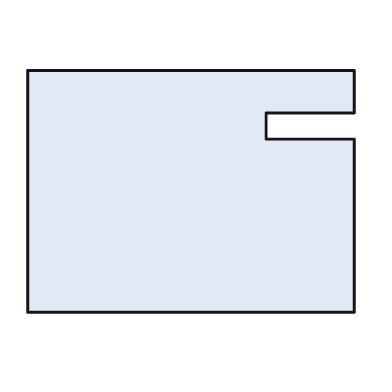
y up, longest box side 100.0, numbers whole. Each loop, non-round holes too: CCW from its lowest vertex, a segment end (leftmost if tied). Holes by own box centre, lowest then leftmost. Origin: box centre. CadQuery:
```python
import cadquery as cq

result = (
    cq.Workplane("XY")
    .moveTo(-50.0, -37.0)
    .lineTo(50.0, -37.0)
    .lineTo(50.0, 16.0)
    .lineTo(23.0, 16.0)
    .lineTo(23.0, 24.0)
    .lineTo(50.0, 24.0)
    .lineTo(50.0, 37.0)
    .lineTo(-50.0, 37.0)
    .close()
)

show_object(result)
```